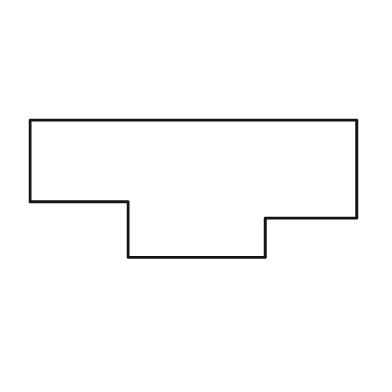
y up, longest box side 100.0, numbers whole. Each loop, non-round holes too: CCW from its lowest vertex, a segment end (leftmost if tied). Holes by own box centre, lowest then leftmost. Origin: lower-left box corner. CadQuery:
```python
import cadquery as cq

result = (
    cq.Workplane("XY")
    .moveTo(30.0, 0.0)
    .lineTo(72.0, 0.0)
    .lineTo(72.0, 12.0)
    .lineTo(100.0, 12.0)
    .lineTo(100.0, 42.0)
    .lineTo(0.0, 42.0)
    .lineTo(0.0, 17.0)
    .lineTo(30.0, 17.0)
    .close()
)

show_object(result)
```